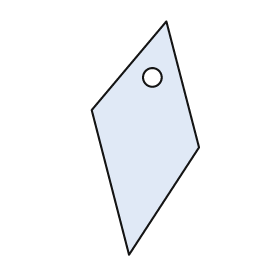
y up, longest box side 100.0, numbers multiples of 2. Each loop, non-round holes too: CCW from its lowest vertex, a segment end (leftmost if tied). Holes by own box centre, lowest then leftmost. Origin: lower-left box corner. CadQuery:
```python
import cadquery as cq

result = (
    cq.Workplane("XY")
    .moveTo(16.0, 0.0)
    .lineTo(46.0, 46.0)
    .lineTo(32.0, 100.0)
    .lineTo(0.0, 62.0)
    .close()
    .moveTo(26.0, 76.0)
    .circle(4.0)
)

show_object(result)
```